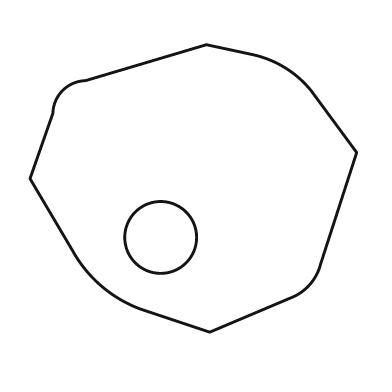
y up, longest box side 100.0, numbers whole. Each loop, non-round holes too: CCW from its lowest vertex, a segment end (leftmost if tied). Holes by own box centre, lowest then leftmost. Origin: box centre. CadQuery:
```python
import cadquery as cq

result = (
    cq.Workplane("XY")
    .moveTo(5.0, -44.0)
    .lineTo(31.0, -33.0)
    .threePointArc((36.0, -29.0), (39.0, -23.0))
    .lineTo(50.0, 11.0)
    .lineTo(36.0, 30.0)
    .threePointArc((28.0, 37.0), (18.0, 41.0))
    .lineTo(4.0, 44.0)
    .lineTo(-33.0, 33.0)
    .threePointArc((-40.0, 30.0), (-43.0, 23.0))
    .lineTo(-50.0, 3.0)
    .lineTo(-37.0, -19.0)
    .threePointArc((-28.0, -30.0), (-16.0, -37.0))
    .close()
    .moveTo(-10.0, -15.0)
    .circle(11.0)
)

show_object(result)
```